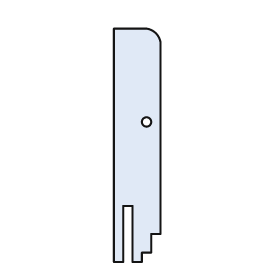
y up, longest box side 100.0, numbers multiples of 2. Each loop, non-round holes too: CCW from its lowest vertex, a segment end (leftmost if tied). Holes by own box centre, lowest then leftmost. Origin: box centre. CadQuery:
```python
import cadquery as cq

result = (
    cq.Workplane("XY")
    .moveTo(-10.0, -50.0)
    .lineTo(-6.0, -50.0)
    .lineTo(-6.0, -26.0)
    .lineTo(-2.0, -26.0)
    .lineTo(-2.0, -50.0)
    .lineTo(2.0, -50.0)
    .lineTo(2.0, -46.0)
    .lineTo(6.0, -46.0)
    .lineTo(6.0, -38.0)
    .lineTo(10.0, -38.0)
    .lineTo(10.0, 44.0)
    .threePointArc((8.0, 48.0), (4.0, 50.0))
    .lineTo(-10.0, 50.0)
    .close()
    .moveTo(4.0, 10.0)
    .circle(2.0)
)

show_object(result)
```